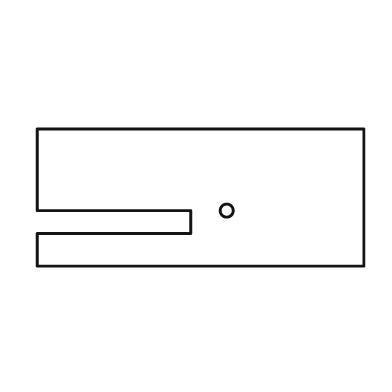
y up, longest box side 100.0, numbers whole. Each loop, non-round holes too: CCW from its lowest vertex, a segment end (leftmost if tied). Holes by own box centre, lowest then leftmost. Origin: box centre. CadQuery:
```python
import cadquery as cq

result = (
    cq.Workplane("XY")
    .moveTo(-50.0, -21.0)
    .lineTo(50.0, -21.0)
    .lineTo(50.0, 21.0)
    .lineTo(-50.0, 21.0)
    .lineTo(-50.0, -4.0)
    .lineTo(-3.0, -4.0)
    .lineTo(-3.0, -11.0)
    .lineTo(-50.0, -11.0)
    .close()
    .moveTo(8.0, -4.0)
    .circle(2.0)
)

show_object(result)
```